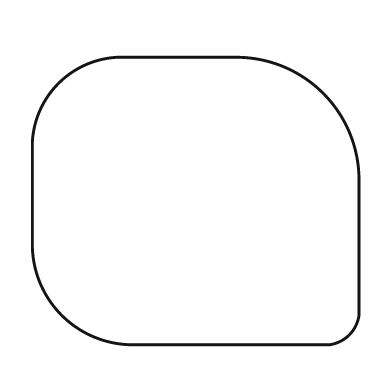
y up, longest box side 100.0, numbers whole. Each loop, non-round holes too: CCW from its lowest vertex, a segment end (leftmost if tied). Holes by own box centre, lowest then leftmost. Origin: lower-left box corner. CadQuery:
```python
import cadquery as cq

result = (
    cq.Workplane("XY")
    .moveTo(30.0, 0.0)
    .lineTo(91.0, 0.0)
    .threePointArc((97.0, 3.0), (100.0, 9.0))
    .lineTo(100.0, 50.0)
    .threePointArc((89.0, 77.0), (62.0, 88.0))
    .lineTo(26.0, 88.0)
    .threePointArc((8.0, 80.0), (0.0, 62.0))
    .lineTo(0.0, 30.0)
    .threePointArc((9.0, 9.0), (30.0, 0.0))
    .close()
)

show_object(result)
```